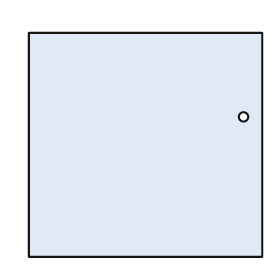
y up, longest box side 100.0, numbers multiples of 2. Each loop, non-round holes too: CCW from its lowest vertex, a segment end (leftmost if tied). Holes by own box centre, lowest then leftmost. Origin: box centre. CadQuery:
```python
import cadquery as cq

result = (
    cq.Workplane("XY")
    .moveTo(-50.0, -48.0)
    .lineTo(50.0, -48.0)
    .lineTo(50.0, 48.0)
    .lineTo(-50.0, 48.0)
    .close()
    .moveTo(42.0, 12.0)
    .circle(2.0)
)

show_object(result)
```